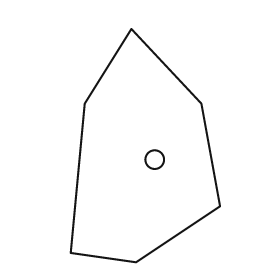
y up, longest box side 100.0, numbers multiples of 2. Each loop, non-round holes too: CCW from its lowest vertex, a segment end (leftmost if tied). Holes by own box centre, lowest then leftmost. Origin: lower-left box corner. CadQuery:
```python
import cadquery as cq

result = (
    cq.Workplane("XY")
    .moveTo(28.0, 0.0)
    .lineTo(64.0, 24.0)
    .lineTo(56.0, 68.0)
    .lineTo(26.0, 100.0)
    .lineTo(6.0, 68.0)
    .lineTo(0.0, 4.0)
    .close()
    .moveTo(36.0, 44.0)
    .circle(4.0)
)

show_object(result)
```